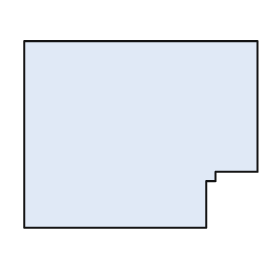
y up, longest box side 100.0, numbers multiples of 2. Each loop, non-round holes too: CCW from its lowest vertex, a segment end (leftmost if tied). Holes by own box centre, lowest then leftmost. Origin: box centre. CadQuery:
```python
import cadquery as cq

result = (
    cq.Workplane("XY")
    .moveTo(-50.0, -40.0)
    .lineTo(28.0, -40.0)
    .lineTo(28.0, -20.0)
    .lineTo(32.0, -20.0)
    .lineTo(32.0, -16.0)
    .lineTo(50.0, -16.0)
    .lineTo(50.0, 40.0)
    .lineTo(-50.0, 40.0)
    .close()
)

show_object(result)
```